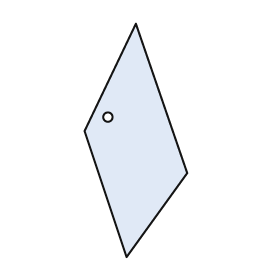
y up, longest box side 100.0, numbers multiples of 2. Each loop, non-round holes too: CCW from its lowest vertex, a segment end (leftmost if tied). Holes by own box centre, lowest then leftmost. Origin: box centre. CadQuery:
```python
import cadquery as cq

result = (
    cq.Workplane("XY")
    .moveTo(-4.0, -50.0)
    .lineTo(22.0, -14.0)
    .lineTo(0.0, 50.0)
    .lineTo(-22.0, 4.0)
    .close()
    .moveTo(-12.0, 10.0)
    .circle(2.0)
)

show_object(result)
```